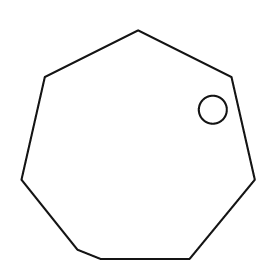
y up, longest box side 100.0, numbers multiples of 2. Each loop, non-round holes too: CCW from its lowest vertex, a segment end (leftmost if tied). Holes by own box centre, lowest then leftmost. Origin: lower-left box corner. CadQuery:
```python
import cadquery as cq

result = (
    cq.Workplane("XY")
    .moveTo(34.0, 0.0)
    .lineTo(72.0, 0.0)
    .lineTo(100.0, 34.0)
    .lineTo(90.0, 78.0)
    .lineTo(50.0, 98.0)
    .lineTo(10.0, 78.0)
    .lineTo(0.0, 34.0)
    .lineTo(24.0, 4.0)
    .close()
    .moveTo(82.0, 64.0)
    .circle(6.0)
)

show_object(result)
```